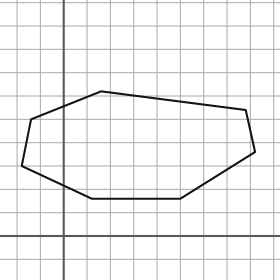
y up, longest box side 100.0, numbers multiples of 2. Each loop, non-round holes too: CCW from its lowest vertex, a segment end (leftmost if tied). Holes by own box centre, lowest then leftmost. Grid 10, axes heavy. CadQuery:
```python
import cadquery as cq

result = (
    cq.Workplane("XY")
    .moveTo(12.0, 16.0)
    .lineTo(50.0, 16.0)
    .lineTo(82.0, 36.0)
    .lineTo(78.0, 54.0)
    .lineTo(16.0, 62.0)
    .lineTo(-14.0, 50.0)
    .lineTo(-18.0, 30.0)
    .close()
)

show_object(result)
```